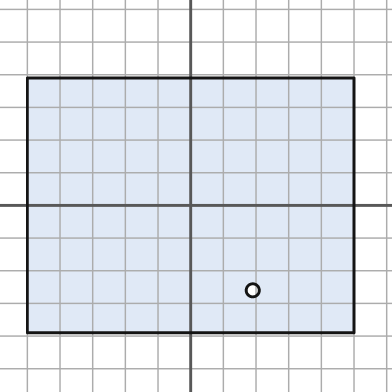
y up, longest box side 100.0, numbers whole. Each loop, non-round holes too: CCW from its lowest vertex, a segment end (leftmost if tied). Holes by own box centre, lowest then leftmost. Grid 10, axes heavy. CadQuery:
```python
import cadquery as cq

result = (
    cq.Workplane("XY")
    .moveTo(-50.0, -39.0)
    .lineTo(50.0, -39.0)
    .lineTo(50.0, 39.0)
    .lineTo(-50.0, 39.0)
    .close()
    .moveTo(19.0, -26.0)
    .circle(2.0)
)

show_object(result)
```